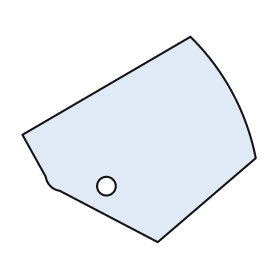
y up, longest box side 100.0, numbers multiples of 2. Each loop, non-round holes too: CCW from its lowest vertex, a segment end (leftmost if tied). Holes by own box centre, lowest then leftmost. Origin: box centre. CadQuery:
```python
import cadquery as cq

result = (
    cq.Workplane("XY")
    .moveTo(8.0, -44.0)
    .lineTo(50.0, -8.0)
    .threePointArc((40.0, 20.0), (22.0, 44.0))
    .lineTo(-50.0, 2.0)
    .lineTo(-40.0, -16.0)
    .threePointArc((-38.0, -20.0), (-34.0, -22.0))
    .close()
    .moveTo(-14.0, -20.0)
    .circle(4.0)
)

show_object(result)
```